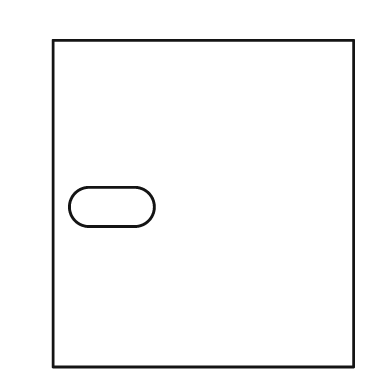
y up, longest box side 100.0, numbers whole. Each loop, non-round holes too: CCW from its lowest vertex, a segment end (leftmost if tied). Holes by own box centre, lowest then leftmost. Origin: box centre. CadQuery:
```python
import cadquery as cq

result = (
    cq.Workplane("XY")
    .moveTo(-46.0, -50.0)
    .lineTo(46.0, -50.0)
    .lineTo(46.0, 50.0)
    .lineTo(-46.0, 50.0)
    .close()
    .moveTo(-35.0, -7.0)
    .lineTo(-21.0, -7.0)
    .threePointArc((-15.0, -1.0), (-21.0, 5.0))
    .lineTo(-35.0, 5.0)
    .threePointArc((-41.0, -1.0), (-35.0, -7.0))
    .close()
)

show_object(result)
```